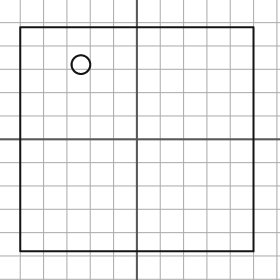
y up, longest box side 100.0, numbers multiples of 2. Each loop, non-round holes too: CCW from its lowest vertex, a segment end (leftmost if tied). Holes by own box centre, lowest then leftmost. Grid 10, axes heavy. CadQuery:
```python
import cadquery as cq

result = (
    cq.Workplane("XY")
    .moveTo(-50.0, -48.0)
    .lineTo(50.0, -48.0)
    .lineTo(50.0, 48.0)
    .lineTo(-50.0, 48.0)
    .close()
    .moveTo(-24.0, 32.0)
    .circle(4.0)
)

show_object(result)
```